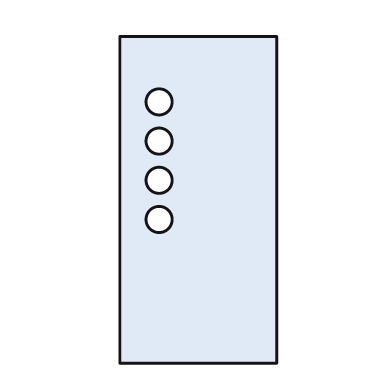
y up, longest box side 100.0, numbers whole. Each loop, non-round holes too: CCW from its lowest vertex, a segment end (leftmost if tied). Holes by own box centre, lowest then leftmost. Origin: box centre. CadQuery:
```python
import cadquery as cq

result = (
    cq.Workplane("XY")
    .moveTo(-24.0, -50.0)
    .lineTo(24.0, -50.0)
    .lineTo(24.0, 50.0)
    .lineTo(-24.0, 50.0)
    .close()
    .moveTo(-12.0, -6.0)
    .circle(4.0)
    .moveTo(-12.0, 6.0)
    .circle(4.0)
    .moveTo(-12.0, 18.0)
    .circle(4.0)
    .moveTo(-12.0, 30.0)
    .circle(4.0)
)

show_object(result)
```